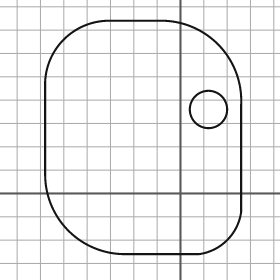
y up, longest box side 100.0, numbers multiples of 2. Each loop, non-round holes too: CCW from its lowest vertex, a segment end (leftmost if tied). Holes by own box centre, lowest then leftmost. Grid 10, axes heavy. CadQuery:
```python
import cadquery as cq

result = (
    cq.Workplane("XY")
    .moveTo(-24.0, -26.0)
    .lineTo(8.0, -26.0)
    .threePointArc((20.0, -20.0), (26.0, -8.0))
    .lineTo(26.0, 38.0)
    .threePointArc((16.0, 64.0), (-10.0, 74.0))
    .lineTo(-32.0, 74.0)
    .threePointArc((-50.0, 66.0), (-58.0, 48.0))
    .lineTo(-58.0, 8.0)
    .threePointArc((-48.0, -16.0), (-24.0, -26.0))
    .close()
    .moveTo(12.0, 36.0)
    .circle(8.0)
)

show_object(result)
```